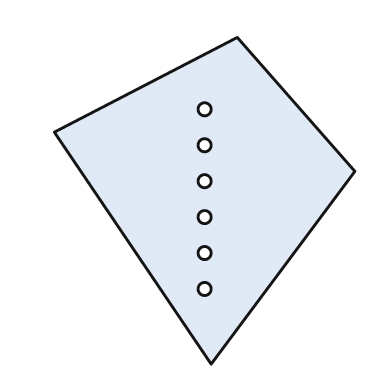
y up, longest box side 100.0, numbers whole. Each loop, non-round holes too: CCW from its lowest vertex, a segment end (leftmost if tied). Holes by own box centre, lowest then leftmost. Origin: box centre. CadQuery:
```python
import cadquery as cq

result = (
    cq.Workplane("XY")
    .moveTo(2.0, -50.0)
    .lineTo(46.0, 9.0)
    .lineTo(10.0, 50.0)
    .lineTo(-46.0, 21.0)
    .close()
    .moveTo(0.0, -27.0)
    .circle(2.0)
    .moveTo(0.0, -16.0)
    .circle(2.0)
    .moveTo(0.0, -5.0)
    .circle(2.0)
    .moveTo(0.0, 6.0)
    .circle(2.0)
    .moveTo(0.0, 17.0)
    .circle(2.0)
    .moveTo(0.0, 28.0)
    .circle(2.0)
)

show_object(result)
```